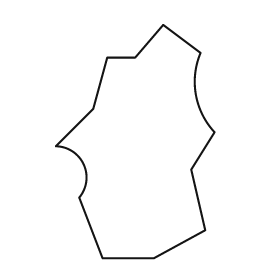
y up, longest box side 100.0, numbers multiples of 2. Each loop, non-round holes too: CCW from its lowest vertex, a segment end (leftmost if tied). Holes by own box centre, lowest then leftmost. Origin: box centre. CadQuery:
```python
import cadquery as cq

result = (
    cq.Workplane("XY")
    .moveTo(-14.0, -50.0)
    .lineTo(8.0, -50.0)
    .lineTo(30.0, -38.0)
    .lineTo(24.0, -12.0)
    .lineTo(34.0, 4.0)
    .threePointArc((26.0, 20.0), (28.0, 38.0))
    .lineTo(12.0, 50.0)
    .lineTo(0.0, 36.0)
    .lineTo(-12.0, 36.0)
    .lineTo(-18.0, 14.0)
    .lineTo(-34.0, -2.0)
    .threePointArc((-22.0, -10.0), (-24.0, -24.0))
    .close()
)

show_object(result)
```